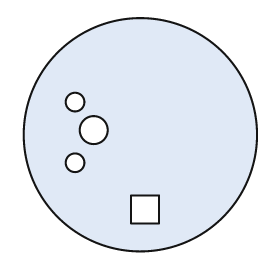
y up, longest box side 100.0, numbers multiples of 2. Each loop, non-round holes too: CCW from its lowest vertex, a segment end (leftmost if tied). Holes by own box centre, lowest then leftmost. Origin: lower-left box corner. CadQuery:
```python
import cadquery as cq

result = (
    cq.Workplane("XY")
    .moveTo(50.0, 50.0)
    .circle(50.0)
    .moveTo(46.0, 12.0)
    .lineTo(58.0, 12.0)
    .lineTo(58.0, 24.0)
    .lineTo(46.0, 24.0)
    .close()
    .moveTo(22.0, 38.0)
    .circle(4.0)
    .moveTo(30.0, 52.0)
    .circle(6.0)
    .moveTo(22.0, 64.0)
    .circle(4.0)
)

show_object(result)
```